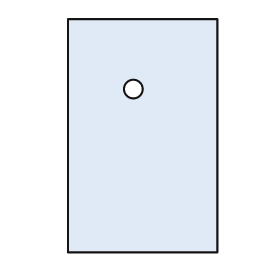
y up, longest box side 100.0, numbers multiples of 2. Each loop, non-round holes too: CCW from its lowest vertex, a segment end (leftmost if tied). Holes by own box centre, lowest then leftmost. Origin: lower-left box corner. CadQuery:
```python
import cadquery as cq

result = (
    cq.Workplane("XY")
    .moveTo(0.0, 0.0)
    .lineTo(64.0, 0.0)
    .lineTo(64.0, 100.0)
    .lineTo(0.0, 100.0)
    .close()
    .moveTo(28.0, 70.0)
    .circle(4.0)
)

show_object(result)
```